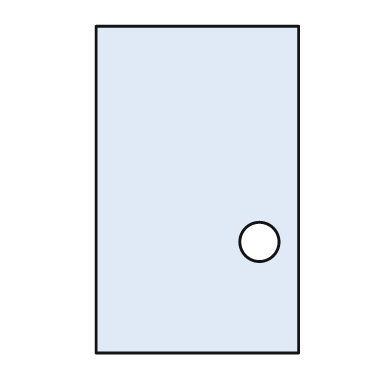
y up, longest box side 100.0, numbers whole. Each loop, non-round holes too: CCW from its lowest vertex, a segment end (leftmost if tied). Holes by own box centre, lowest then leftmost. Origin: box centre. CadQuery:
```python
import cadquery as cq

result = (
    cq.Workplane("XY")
    .moveTo(-31.0, -50.0)
    .lineTo(31.0, -50.0)
    .lineTo(31.0, 50.0)
    .lineTo(-31.0, 50.0)
    .close()
    .moveTo(19.0, -16.0)
    .circle(6.0)
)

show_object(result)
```